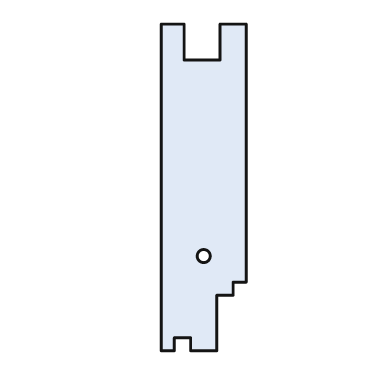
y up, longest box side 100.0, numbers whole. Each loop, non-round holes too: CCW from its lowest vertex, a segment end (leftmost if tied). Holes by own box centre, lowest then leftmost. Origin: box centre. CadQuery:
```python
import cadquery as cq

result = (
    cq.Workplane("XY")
    .moveTo(-13.0, -50.0)
    .lineTo(-9.0, -50.0)
    .lineTo(-9.0, -46.0)
    .lineTo(-4.0, -46.0)
    .lineTo(-4.0, -50.0)
    .lineTo(4.0, -50.0)
    .lineTo(4.0, -33.0)
    .lineTo(9.0, -33.0)
    .lineTo(9.0, -29.0)
    .lineTo(13.0, -29.0)
    .lineTo(13.0, 50.0)
    .lineTo(5.0, 50.0)
    .lineTo(5.0, 39.0)
    .lineTo(-6.0, 39.0)
    .lineTo(-6.0, 50.0)
    .lineTo(-13.0, 50.0)
    .close()
    .moveTo(0.0, -21.0)
    .circle(2.0)
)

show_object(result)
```